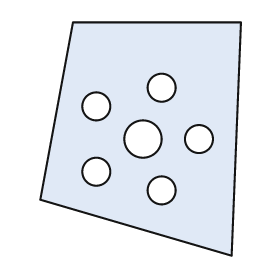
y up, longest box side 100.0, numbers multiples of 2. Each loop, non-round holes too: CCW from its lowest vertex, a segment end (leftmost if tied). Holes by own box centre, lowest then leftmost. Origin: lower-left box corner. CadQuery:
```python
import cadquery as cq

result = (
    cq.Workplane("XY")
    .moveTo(82.0, 0.0)
    .lineTo(86.0, 100.0)
    .lineTo(14.0, 100.0)
    .lineTo(0.0, 24.0)
    .close()
    .moveTo(52.0, 28.0)
    .circle(6.0)
    .moveTo(24.0, 36.0)
    .circle(6.0)
    .moveTo(44.0, 50.0)
    .circle(8.0)
    .moveTo(68.0, 50.0)
    .circle(6.0)
    .moveTo(24.0, 64.0)
    .circle(6.0)
    .moveTo(52.0, 72.0)
    .circle(6.0)
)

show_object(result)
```